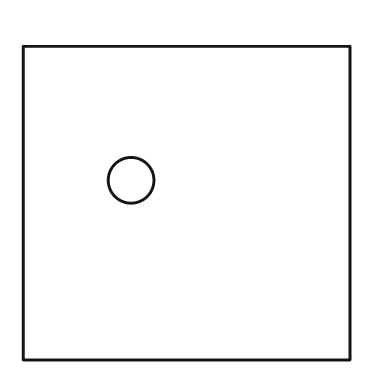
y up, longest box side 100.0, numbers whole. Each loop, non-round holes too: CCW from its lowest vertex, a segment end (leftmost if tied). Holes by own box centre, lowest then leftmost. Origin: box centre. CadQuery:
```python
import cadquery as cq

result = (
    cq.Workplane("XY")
    .moveTo(-50.0, -48.0)
    .lineTo(50.0, -48.0)
    .lineTo(50.0, 48.0)
    .lineTo(-50.0, 48.0)
    .close()
    .moveTo(-17.0, 7.0)
    .circle(7.0)
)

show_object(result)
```